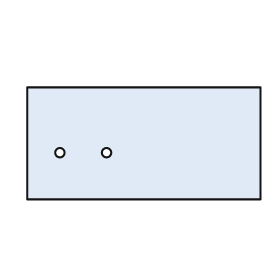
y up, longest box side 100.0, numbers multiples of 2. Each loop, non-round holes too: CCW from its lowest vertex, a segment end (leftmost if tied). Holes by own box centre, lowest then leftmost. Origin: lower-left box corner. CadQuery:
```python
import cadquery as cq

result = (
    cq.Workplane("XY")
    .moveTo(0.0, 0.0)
    .lineTo(100.0, 0.0)
    .lineTo(100.0, 48.0)
    .lineTo(0.0, 48.0)
    .close()
    .moveTo(14.0, 20.0)
    .circle(2.0)
    .moveTo(34.0, 20.0)
    .circle(2.0)
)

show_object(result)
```